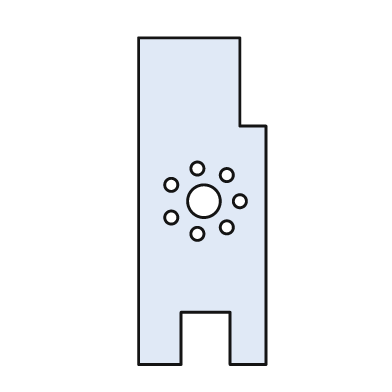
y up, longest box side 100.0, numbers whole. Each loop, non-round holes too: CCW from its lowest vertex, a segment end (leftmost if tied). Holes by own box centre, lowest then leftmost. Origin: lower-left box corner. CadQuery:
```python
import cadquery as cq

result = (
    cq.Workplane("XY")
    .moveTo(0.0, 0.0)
    .lineTo(13.0, 0.0)
    .lineTo(13.0, 16.0)
    .lineTo(28.0, 16.0)
    .lineTo(28.0, 0.0)
    .lineTo(39.0, 0.0)
    .lineTo(39.0, 73.0)
    .lineTo(31.0, 73.0)
    .lineTo(31.0, 100.0)
    .lineTo(0.0, 100.0)
    .close()
    .moveTo(18.0, 40.0)
    .circle(2.0)
    .moveTo(27.0, 42.0)
    .circle(2.0)
    .moveTo(10.0, 45.0)
    .circle(2.0)
    .moveTo(20.0, 50.0)
    .circle(5.0)
    .moveTo(31.0, 50.0)
    .circle(2.0)
    .moveTo(10.0, 55.0)
    .circle(2.0)
    .moveTo(27.0, 58.0)
    .circle(2.0)
    .moveTo(18.0, 60.0)
    .circle(2.0)
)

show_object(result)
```